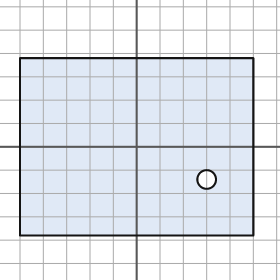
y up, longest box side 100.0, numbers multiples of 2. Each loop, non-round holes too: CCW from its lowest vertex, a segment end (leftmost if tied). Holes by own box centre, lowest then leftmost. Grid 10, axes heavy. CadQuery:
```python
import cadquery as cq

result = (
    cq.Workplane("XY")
    .moveTo(-50.0, -38.0)
    .lineTo(50.0, -38.0)
    .lineTo(50.0, 38.0)
    .lineTo(-50.0, 38.0)
    .close()
    .moveTo(30.0, -14.0)
    .circle(4.0)
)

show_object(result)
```